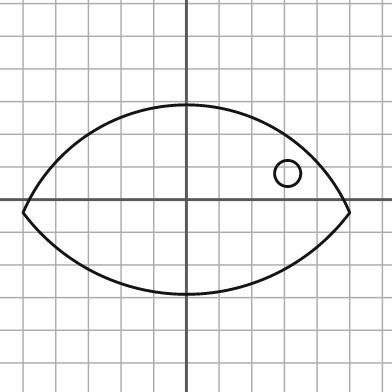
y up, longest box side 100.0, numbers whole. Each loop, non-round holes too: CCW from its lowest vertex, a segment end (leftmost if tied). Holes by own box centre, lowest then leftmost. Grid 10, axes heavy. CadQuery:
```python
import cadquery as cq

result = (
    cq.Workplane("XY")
    .moveTo(-50.0, -4.0)
    .threePointArc((0.0, -29.0), (50.0, -4.0))
    .threePointArc((0.0, 29.0), (-50.0, -4.0))
    .close()
    .moveTo(31.0, 8.0)
    .circle(4.0)
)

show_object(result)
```